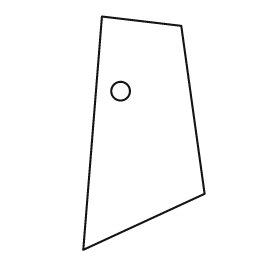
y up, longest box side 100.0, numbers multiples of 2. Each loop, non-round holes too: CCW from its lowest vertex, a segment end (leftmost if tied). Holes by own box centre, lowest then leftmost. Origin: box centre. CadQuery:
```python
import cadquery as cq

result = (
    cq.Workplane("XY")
    .moveTo(-26.0, -50.0)
    .lineTo(26.0, -26.0)
    .lineTo(16.0, 46.0)
    .lineTo(-18.0, 50.0)
    .close()
    .moveTo(-10.0, 18.0)
    .circle(4.0)
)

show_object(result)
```